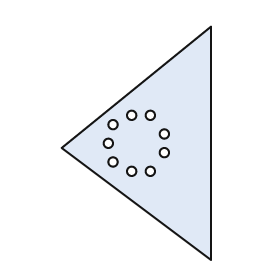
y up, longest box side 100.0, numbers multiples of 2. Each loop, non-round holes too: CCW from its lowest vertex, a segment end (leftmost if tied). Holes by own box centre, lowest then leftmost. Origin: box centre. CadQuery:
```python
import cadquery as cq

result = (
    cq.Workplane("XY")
    .moveTo(32.0, -50.0)
    .lineTo(32.0, 50.0)
    .lineTo(-32.0, -2.0)
    .close()
    .moveTo(-2.0, -12.0)
    .circle(2.0)
    .moveTo(6.0, -12.0)
    .circle(2.0)
    .moveTo(-10.0, -8.0)
    .circle(2.0)
    .moveTo(12.0, -4.0)
    .circle(2.0)
    .moveTo(-12.0, 0.0)
    .circle(2.0)
    .moveTo(12.0, 4.0)
    .circle(2.0)
    .moveTo(-10.0, 8.0)
    .circle(2.0)
    .moveTo(-2.0, 12.0)
    .circle(2.0)
    .moveTo(6.0, 12.0)
    .circle(2.0)
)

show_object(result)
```